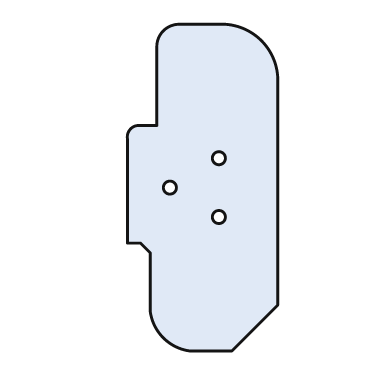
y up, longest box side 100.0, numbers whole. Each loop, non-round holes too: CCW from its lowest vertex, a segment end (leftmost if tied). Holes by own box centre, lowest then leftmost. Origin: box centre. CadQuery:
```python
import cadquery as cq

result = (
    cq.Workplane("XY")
    .moveTo(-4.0, -50.0)
    .lineTo(9.0, -50.0)
    .lineTo(23.0, -36.0)
    .lineTo(23.0, 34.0)
    .threePointArc((18.0, 45.0), (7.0, 50.0))
    .lineTo(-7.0, 50.0)
    .threePointArc((-12.0, 48.0), (-14.0, 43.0))
    .lineTo(-14.0, 19.0)
    .lineTo(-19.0, 19.0)
    .threePointArc((-22.0, 18.0), (-23.0, 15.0))
    .lineTo(-23.0, -17.0)
    .lineTo(-19.0, -17.0)
    .lineTo(-16.0, -20.0)
    .lineTo(-16.0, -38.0)
    .threePointArc((-12.0, -46.0), (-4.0, -50.0))
    .close()
    .moveTo(5.0, -9.0)
    .circle(2.0)
    .moveTo(-10.0, 0.0)
    .circle(2.0)
    .moveTo(5.0, 9.0)
    .circle(2.0)
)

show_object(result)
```